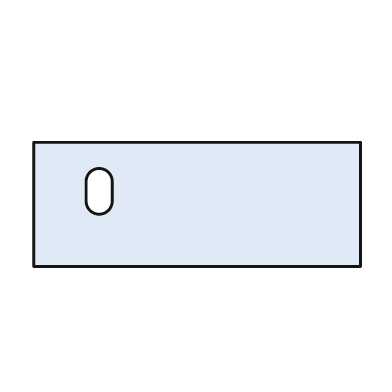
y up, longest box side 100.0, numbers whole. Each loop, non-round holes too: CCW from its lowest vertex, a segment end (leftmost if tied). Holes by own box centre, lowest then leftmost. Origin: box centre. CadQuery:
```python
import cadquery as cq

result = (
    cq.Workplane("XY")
    .moveTo(-50.0, -19.0)
    .lineTo(50.0, -19.0)
    .lineTo(50.0, 19.0)
    .lineTo(-50.0, 19.0)
    .close()
    .moveTo(-34.0, 1.0)
    .threePointArc((-30.0, -3.0), (-26.0, 1.0))
    .lineTo(-26.0, 7.0)
    .threePointArc((-30.0, 11.0), (-34.0, 7.0))
    .close()
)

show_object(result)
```